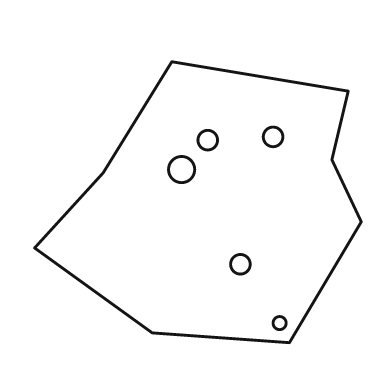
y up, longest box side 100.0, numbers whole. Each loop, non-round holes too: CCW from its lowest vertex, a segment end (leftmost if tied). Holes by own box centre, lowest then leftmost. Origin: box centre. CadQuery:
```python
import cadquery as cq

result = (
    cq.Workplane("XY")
    .moveTo(28.0, -43.0)
    .lineTo(50.0, -6.0)
    .lineTo(41.0, 13.0)
    .lineTo(46.0, 34.0)
    .lineTo(-8.0, 43.0)
    .lineTo(-29.0, 9.0)
    .lineTo(-50.0, -14.0)
    .lineTo(-14.0, -40.0)
    .close()
    .moveTo(25.0, -37.0)
    .circle(2.0)
    .moveTo(13.0, -19.0)
    .circle(3.0)
    .moveTo(-5.0, 10.0)
    .circle(4.0)
    .moveTo(3.0, 19.0)
    .circle(3.0)
    .moveTo(23.0, 20.0)
    .circle(3.0)
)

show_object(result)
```